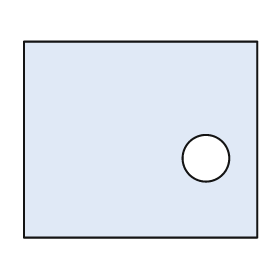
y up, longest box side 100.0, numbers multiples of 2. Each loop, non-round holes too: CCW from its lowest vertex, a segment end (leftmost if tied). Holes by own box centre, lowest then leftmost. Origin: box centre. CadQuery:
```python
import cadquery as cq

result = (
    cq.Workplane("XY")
    .moveTo(-50.0, -42.0)
    .lineTo(50.0, -42.0)
    .lineTo(50.0, 42.0)
    .lineTo(-50.0, 42.0)
    .close()
    .moveTo(28.0, -8.0)
    .circle(10.0)
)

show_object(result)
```